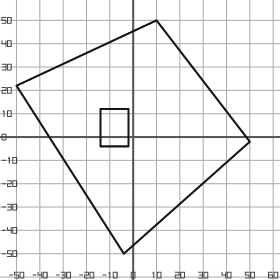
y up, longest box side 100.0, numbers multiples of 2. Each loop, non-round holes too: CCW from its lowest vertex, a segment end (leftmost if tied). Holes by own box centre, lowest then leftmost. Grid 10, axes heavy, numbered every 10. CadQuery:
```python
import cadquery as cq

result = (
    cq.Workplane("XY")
    .moveTo(-4.0, -50.0)
    .lineTo(50.0, -2.0)
    .lineTo(10.0, 50.0)
    .lineTo(-50.0, 22.0)
    .close()
    .moveTo(-14.0, -4.0)
    .lineTo(-2.0, -4.0)
    .lineTo(-2.0, 12.0)
    .lineTo(-14.0, 12.0)
    .close()
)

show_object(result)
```